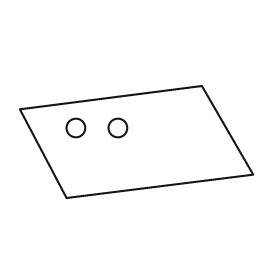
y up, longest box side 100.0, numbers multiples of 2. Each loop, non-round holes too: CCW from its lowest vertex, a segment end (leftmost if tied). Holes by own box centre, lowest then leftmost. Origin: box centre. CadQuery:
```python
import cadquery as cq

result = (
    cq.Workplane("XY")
    .moveTo(-30.0, -24.0)
    .lineTo(50.0, -14.0)
    .lineTo(28.0, 24.0)
    .lineTo(-50.0, 14.0)
    .close()
    .moveTo(-26.0, 6.0)
    .circle(4.0)
    .moveTo(-8.0, 6.0)
    .circle(4.0)
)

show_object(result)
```